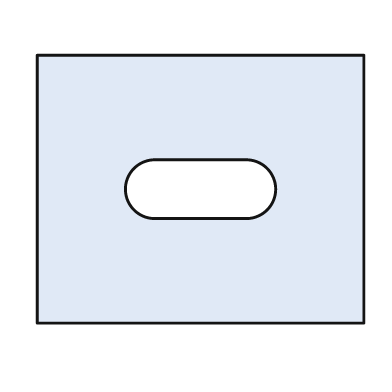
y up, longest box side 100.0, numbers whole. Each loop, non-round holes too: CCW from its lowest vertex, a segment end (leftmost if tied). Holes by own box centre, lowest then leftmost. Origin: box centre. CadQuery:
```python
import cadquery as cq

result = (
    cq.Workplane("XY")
    .moveTo(-50.0, -41.0)
    .lineTo(50.0, -41.0)
    .lineTo(50.0, 41.0)
    .lineTo(-50.0, 41.0)
    .close()
    .moveTo(-14.0, -9.0)
    .lineTo(14.0, -9.0)
    .threePointArc((23.0, 0.0), (14.0, 9.0))
    .lineTo(-14.0, 9.0)
    .threePointArc((-23.0, 0.0), (-14.0, -9.0))
    .close()
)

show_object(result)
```